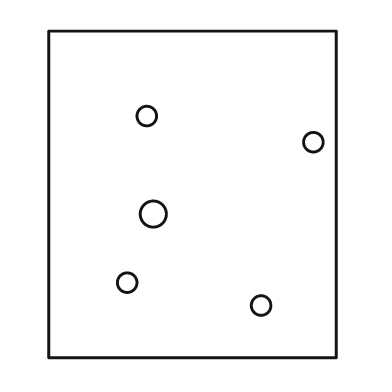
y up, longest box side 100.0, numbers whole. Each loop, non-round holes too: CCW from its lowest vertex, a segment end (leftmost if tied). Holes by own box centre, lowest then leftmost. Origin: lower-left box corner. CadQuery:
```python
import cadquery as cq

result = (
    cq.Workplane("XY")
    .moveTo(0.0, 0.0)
    .lineTo(88.0, 0.0)
    .lineTo(88.0, 100.0)
    .lineTo(0.0, 100.0)
    .close()
    .moveTo(65.0, 16.0)
    .circle(3.0)
    .moveTo(24.0, 23.0)
    .circle(3.0)
    .moveTo(32.0, 44.0)
    .circle(4.0)
    .moveTo(81.0, 66.0)
    .circle(3.0)
    .moveTo(30.0, 74.0)
    .circle(3.0)
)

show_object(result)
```